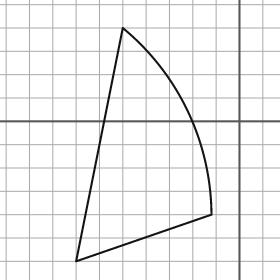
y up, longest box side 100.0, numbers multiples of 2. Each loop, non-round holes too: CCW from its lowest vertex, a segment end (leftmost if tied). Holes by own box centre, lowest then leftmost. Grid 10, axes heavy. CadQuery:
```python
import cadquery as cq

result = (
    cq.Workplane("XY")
    .moveTo(-70.0, -60.0)
    .lineTo(-12.0, -40.0)
    .threePointArc((-22.0, 4.0), (-50.0, 40.0))
    .close()
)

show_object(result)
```